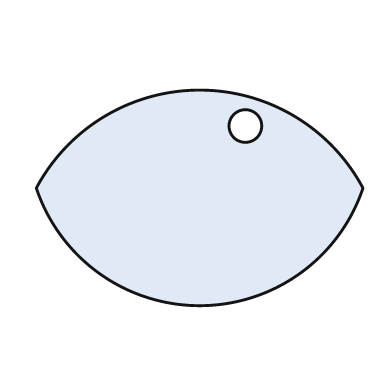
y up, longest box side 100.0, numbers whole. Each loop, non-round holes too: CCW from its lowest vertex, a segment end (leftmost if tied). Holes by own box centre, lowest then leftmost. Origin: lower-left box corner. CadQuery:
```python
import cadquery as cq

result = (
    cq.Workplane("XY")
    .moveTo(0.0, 36.0)
    .threePointArc((50.0, 0.0), (100.0, 36.0))
    .threePointArc((50.0, 66.0), (0.0, 36.0))
    .close()
    .moveTo(64.0, 55.0)
    .circle(5.0)
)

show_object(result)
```